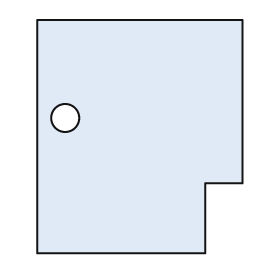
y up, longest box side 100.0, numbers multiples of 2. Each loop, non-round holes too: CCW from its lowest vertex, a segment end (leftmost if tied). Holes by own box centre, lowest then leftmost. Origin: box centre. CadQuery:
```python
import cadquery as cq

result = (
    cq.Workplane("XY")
    .moveTo(-44.0, -50.0)
    .lineTo(28.0, -50.0)
    .lineTo(28.0, -20.0)
    .lineTo(44.0, -20.0)
    .lineTo(44.0, 50.0)
    .lineTo(-44.0, 50.0)
    .close()
    .moveTo(-32.0, 8.0)
    .circle(6.0)
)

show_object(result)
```